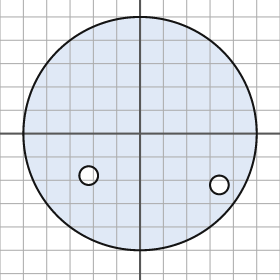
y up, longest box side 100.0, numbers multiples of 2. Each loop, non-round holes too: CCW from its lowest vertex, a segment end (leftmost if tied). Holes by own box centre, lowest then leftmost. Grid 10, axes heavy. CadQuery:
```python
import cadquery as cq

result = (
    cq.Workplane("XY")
    .moveTo(0.0, 0.0)
    .circle(50.0)
    .moveTo(34.0, -22.0)
    .circle(4.0)
    .moveTo(-22.0, -18.0)
    .circle(4.0)
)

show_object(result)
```